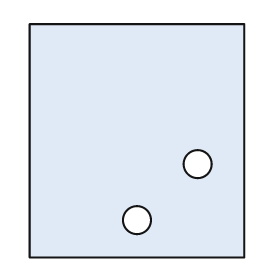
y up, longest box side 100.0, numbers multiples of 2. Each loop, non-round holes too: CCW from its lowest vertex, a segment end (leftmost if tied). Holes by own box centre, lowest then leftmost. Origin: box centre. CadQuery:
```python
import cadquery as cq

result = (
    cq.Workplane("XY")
    .moveTo(-46.0, -50.0)
    .lineTo(46.0, -50.0)
    .lineTo(46.0, 50.0)
    .lineTo(-46.0, 50.0)
    .close()
    .moveTo(0.0, -34.0)
    .circle(6.0)
    .moveTo(26.0, -10.0)
    .circle(6.0)
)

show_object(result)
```